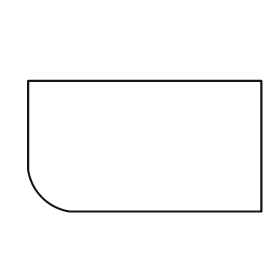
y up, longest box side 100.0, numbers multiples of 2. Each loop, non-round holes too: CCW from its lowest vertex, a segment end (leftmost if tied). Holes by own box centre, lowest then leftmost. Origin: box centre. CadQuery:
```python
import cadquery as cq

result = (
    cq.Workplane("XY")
    .moveTo(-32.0, -28.0)
    .lineTo(50.0, -28.0)
    .lineTo(50.0, 28.0)
    .lineTo(-50.0, 28.0)
    .lineTo(-50.0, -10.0)
    .threePointArc((-44.0, -22.0), (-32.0, -28.0))
    .close()
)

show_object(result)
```